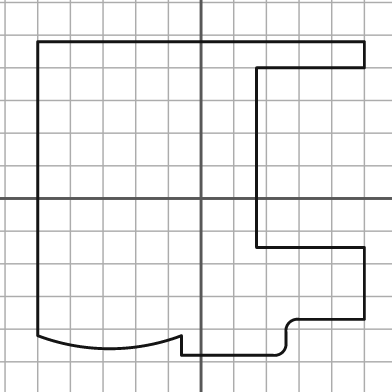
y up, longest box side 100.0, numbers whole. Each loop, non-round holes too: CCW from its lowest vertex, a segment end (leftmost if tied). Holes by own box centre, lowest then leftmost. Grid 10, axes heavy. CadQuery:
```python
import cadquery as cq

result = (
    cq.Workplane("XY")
    .moveTo(-6.0, -48.0)
    .lineTo(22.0, -48.0)
    .threePointArc((25.0, -47.0), (26.0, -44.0))
    .lineTo(26.0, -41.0)
    .threePointArc((27.0, -38.0), (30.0, -37.0))
    .lineTo(50.0, -37.0)
    .lineTo(50.0, -15.0)
    .lineTo(17.0, -15.0)
    .lineTo(17.0, 40.0)
    .lineTo(50.0, 40.0)
    .lineTo(50.0, 48.0)
    .lineTo(-50.0, 48.0)
    .lineTo(-50.0, -42.0)
    .threePointArc((-28.0, -46.0), (-6.0, -42.0))
    .close()
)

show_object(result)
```